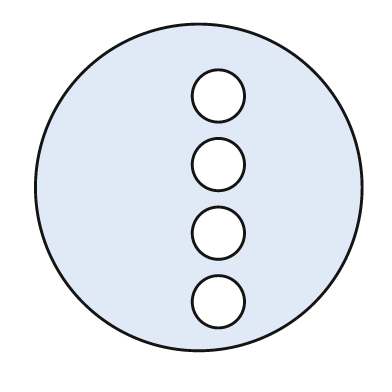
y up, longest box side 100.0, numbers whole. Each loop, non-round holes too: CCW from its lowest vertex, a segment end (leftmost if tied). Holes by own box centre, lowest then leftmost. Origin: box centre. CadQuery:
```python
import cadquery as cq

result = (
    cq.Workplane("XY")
    .moveTo(0.0, 0.0)
    .circle(50.0)
    .moveTo(6.0, -35.0)
    .circle(8.0)
    .moveTo(6.0, -14.0)
    .circle(8.0)
    .moveTo(6.0, 7.0)
    .circle(8.0)
    .moveTo(6.0, 28.0)
    .circle(8.0)
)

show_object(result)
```